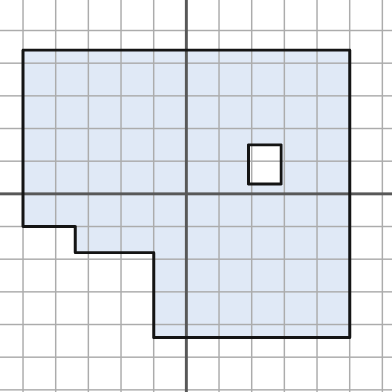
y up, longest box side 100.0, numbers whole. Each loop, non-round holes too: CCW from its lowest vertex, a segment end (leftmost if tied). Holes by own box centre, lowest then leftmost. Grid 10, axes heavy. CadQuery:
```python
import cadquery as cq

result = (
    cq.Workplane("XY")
    .moveTo(-10.0, -44.0)
    .lineTo(50.0, -44.0)
    .lineTo(50.0, 44.0)
    .lineTo(-50.0, 44.0)
    .lineTo(-50.0, -10.0)
    .lineTo(-34.0, -10.0)
    .lineTo(-34.0, -18.0)
    .lineTo(-10.0, -18.0)
    .close()
    .moveTo(19.0, 3.0)
    .lineTo(29.0, 3.0)
    .lineTo(29.0, 15.0)
    .lineTo(19.0, 15.0)
    .close()
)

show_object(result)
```